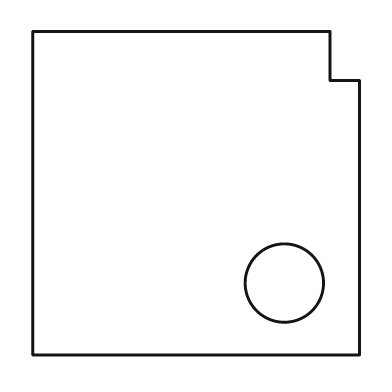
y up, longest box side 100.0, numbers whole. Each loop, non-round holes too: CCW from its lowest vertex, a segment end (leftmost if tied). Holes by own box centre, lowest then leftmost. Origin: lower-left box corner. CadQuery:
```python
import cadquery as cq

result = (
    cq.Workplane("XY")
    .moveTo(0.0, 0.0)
    .lineTo(100.0, 0.0)
    .lineTo(100.0, 84.0)
    .lineTo(91.0, 84.0)
    .lineTo(91.0, 99.0)
    .lineTo(0.0, 99.0)
    .close()
    .moveTo(77.0, 22.0)
    .circle(12.0)
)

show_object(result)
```